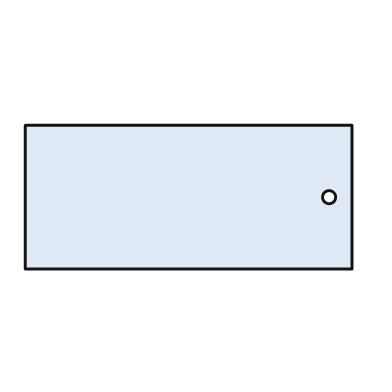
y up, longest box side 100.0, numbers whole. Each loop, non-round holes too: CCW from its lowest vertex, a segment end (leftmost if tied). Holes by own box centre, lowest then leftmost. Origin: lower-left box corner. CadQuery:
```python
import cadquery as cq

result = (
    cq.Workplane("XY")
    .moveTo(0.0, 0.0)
    .lineTo(100.0, 0.0)
    .lineTo(100.0, 44.0)
    .lineTo(0.0, 44.0)
    .close()
    .moveTo(93.0, 22.0)
    .circle(2.0)
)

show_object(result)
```